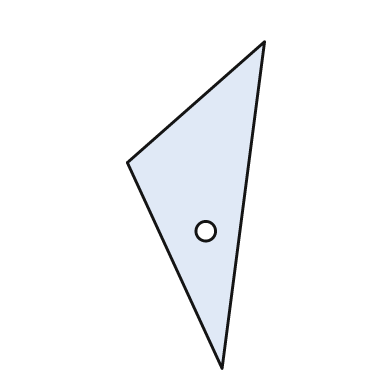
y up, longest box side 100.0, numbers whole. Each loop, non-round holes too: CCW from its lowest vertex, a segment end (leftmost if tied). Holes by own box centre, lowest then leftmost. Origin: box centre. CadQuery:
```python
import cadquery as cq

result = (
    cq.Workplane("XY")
    .moveTo(8.0, -50.0)
    .lineTo(21.0, 50.0)
    .lineTo(-21.0, 13.0)
    .close()
    .moveTo(3.0, -8.0)
    .circle(3.0)
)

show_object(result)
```